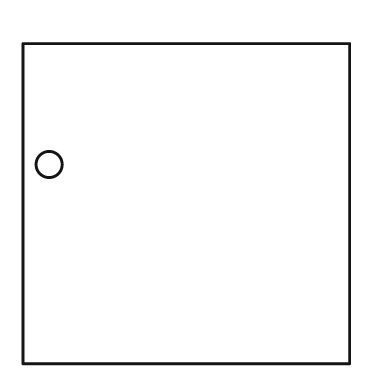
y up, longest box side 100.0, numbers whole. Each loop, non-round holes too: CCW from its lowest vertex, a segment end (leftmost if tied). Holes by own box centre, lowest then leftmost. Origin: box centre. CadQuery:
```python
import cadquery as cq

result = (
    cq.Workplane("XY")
    .moveTo(-50.0, -49.0)
    .lineTo(50.0, -49.0)
    .lineTo(50.0, 49.0)
    .lineTo(-50.0, 49.0)
    .close()
    .moveTo(-42.0, 12.0)
    .circle(4.0)
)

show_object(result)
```